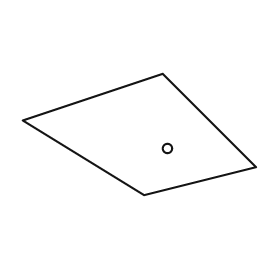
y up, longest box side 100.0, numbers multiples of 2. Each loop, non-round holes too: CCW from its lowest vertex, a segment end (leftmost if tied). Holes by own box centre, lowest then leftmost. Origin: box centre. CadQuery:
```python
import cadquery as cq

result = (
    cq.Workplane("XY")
    .moveTo(2.0, -26.0)
    .lineTo(50.0, -14.0)
    .lineTo(10.0, 26.0)
    .lineTo(-50.0, 6.0)
    .close()
    .moveTo(12.0, -6.0)
    .circle(2.0)
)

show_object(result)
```